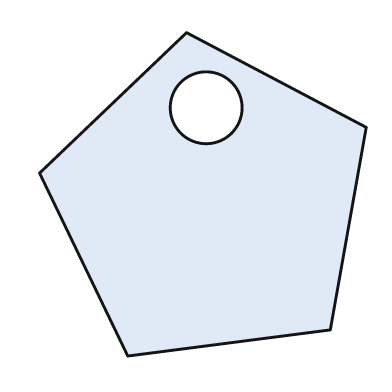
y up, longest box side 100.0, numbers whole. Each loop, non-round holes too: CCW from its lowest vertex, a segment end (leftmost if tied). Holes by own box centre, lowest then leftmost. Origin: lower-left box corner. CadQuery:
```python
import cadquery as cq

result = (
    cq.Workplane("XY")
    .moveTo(27.0, 0.0)
    .lineTo(89.0, 8.0)
    .lineTo(100.0, 70.0)
    .lineTo(45.0, 99.0)
    .lineTo(0.0, 56.0)
    .close()
    .moveTo(51.0, 76.0)
    .circle(11.0)
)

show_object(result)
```